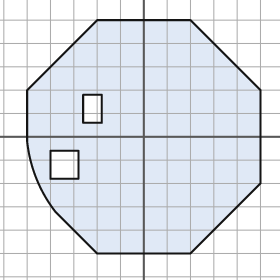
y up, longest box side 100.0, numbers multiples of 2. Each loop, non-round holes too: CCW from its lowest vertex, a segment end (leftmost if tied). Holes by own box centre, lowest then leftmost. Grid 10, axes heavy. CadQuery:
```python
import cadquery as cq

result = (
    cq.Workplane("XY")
    .moveTo(-20.0, -50.0)
    .lineTo(20.0, -50.0)
    .lineTo(50.0, -20.0)
    .lineTo(50.0, 20.0)
    .lineTo(20.0, 50.0)
    .lineTo(-20.0, 50.0)
    .lineTo(-50.0, 20.0)
    .lineTo(-50.0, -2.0)
    .threePointArc((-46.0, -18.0), (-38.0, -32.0))
    .close()
    .moveTo(-40.0, -18.0)
    .lineTo(-28.0, -18.0)
    .lineTo(-28.0, -6.0)
    .lineTo(-40.0, -6.0)
    .close()
    .moveTo(-26.0, 6.0)
    .lineTo(-18.0, 6.0)
    .lineTo(-18.0, 18.0)
    .lineTo(-26.0, 18.0)
    .close()
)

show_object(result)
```